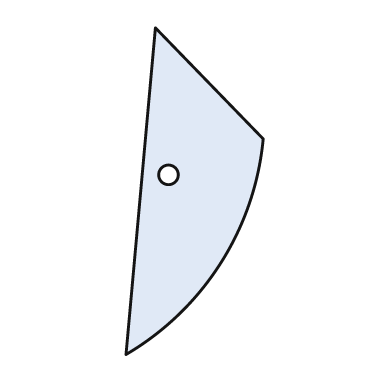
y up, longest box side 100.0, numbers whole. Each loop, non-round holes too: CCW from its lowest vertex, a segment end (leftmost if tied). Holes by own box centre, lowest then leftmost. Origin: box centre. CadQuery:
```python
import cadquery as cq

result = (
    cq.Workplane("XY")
    .moveTo(-21.0, -50.0)
    .threePointArc((8.0, -22.0), (21.0, 16.0))
    .lineTo(-12.0, 50.0)
    .close()
    .moveTo(-8.0, 5.0)
    .circle(3.0)
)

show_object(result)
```